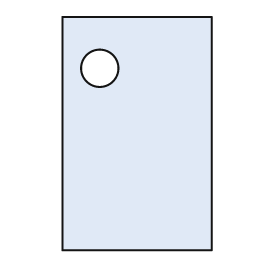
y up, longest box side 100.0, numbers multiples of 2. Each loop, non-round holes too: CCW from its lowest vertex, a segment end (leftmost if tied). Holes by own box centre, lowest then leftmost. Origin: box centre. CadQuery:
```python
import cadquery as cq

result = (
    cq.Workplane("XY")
    .moveTo(-32.0, -50.0)
    .lineTo(32.0, -50.0)
    .lineTo(32.0, 50.0)
    .lineTo(-32.0, 50.0)
    .close()
    .moveTo(-16.0, 28.0)
    .circle(8.0)
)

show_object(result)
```